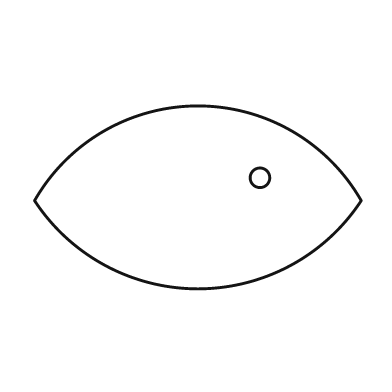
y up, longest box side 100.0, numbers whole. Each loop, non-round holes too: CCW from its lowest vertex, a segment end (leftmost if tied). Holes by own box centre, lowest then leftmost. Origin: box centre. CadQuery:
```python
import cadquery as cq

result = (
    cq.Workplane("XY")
    .moveTo(-50.0, -1.0)
    .threePointArc((0.0, -28.0), (50.0, -1.0))
    .threePointArc((0.0, 28.0), (-50.0, -1.0))
    .close()
    .moveTo(19.0, 6.0)
    .circle(3.0)
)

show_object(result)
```